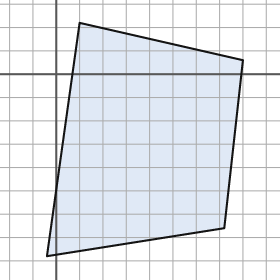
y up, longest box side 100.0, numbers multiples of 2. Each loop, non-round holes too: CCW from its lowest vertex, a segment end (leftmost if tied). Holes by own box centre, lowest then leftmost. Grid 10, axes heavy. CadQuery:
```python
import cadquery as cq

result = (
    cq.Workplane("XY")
    .moveTo(-4.0, -78.0)
    .lineTo(72.0, -66.0)
    .lineTo(80.0, 6.0)
    .lineTo(10.0, 22.0)
    .close()
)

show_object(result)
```